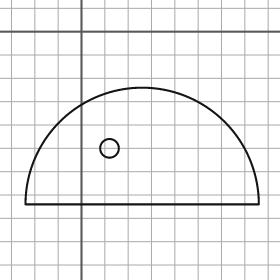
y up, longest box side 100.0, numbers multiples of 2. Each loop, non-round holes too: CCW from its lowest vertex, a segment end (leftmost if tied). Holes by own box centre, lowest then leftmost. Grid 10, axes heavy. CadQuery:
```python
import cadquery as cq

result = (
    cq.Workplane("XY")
    .moveTo(-24.0, -74.0)
    .lineTo(76.0, -74.0)
    .threePointArc((26.0, -24.0), (-24.0, -74.0))
    .close()
    .moveTo(12.0, -50.0)
    .circle(4.0)
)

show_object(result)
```